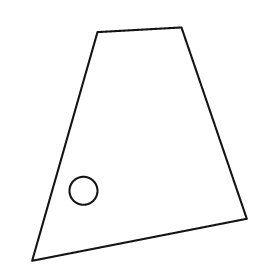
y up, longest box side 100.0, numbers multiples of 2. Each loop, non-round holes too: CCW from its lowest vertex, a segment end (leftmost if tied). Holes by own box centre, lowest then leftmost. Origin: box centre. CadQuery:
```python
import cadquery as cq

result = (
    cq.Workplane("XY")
    .moveTo(-46.0, -50.0)
    .lineTo(46.0, -32.0)
    .lineTo(18.0, 50.0)
    .lineTo(-18.0, 48.0)
    .close()
    .moveTo(-24.0, -20.0)
    .circle(6.0)
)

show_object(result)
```